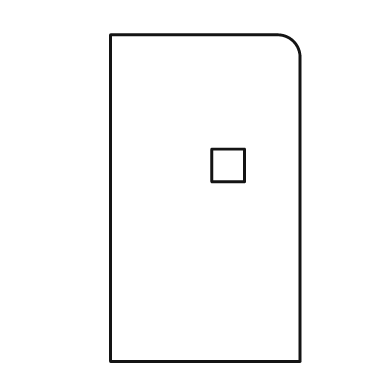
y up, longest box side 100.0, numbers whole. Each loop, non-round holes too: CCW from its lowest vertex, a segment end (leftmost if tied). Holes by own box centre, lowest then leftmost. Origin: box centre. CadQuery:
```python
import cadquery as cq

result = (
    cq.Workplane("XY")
    .moveTo(-29.0, -50.0)
    .lineTo(29.0, -50.0)
    .lineTo(29.0, 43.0)
    .threePointArc((27.0, 48.0), (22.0, 50.0))
    .lineTo(-29.0, 50.0)
    .close()
    .moveTo(2.0, 5.0)
    .lineTo(12.0, 5.0)
    .lineTo(12.0, 15.0)
    .lineTo(2.0, 15.0)
    .close()
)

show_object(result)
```